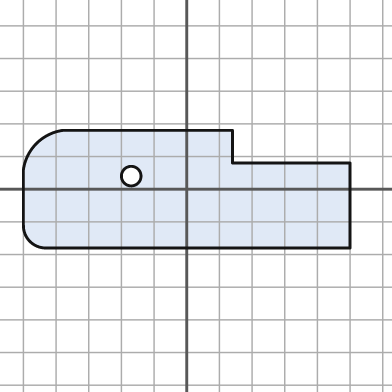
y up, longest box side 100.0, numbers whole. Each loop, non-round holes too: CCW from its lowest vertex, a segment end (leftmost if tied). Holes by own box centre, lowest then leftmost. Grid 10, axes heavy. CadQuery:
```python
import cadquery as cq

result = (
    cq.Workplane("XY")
    .moveTo(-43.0, -18.0)
    .lineTo(50.0, -18.0)
    .lineTo(50.0, 8.0)
    .lineTo(14.0, 8.0)
    .lineTo(14.0, 18.0)
    .lineTo(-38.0, 18.0)
    .threePointArc((-46.0, 14.0), (-50.0, 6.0))
    .lineTo(-50.0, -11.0)
    .threePointArc((-48.0, -16.0), (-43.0, -18.0))
    .close()
    .moveTo(-17.0, 4.0)
    .circle(3.0)
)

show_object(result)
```